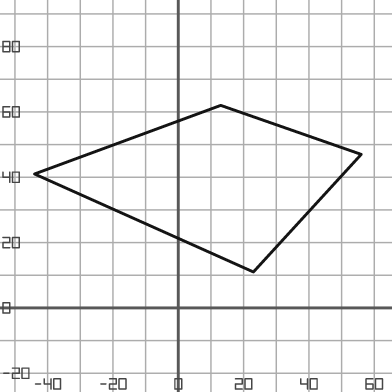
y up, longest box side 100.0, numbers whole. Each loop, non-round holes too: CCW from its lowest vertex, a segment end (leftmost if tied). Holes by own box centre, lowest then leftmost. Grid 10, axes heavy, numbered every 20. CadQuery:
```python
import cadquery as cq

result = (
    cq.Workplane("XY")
    .moveTo(23.0, 11.0)
    .lineTo(56.0, 47.0)
    .lineTo(13.0, 62.0)
    .lineTo(-44.0, 41.0)
    .close()
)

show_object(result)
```